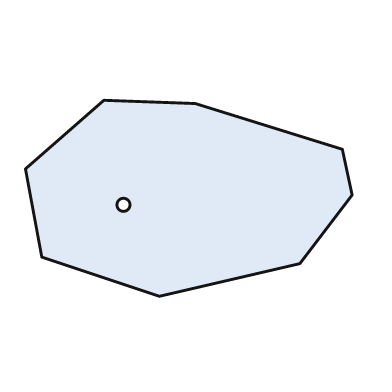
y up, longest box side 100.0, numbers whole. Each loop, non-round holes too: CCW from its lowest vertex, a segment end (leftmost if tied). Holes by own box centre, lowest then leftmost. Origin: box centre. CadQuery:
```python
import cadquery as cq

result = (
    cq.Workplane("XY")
    .moveTo(-9.0, -30.0)
    .lineTo(34.0, -20.0)
    .lineTo(50.0, 1.0)
    .lineTo(47.0, 15.0)
    .lineTo(2.0, 29.0)
    .lineTo(-26.0, 30.0)
    .lineTo(-50.0, 9.0)
    .lineTo(-45.0, -18.0)
    .close()
    .moveTo(-20.0, -2.0)
    .circle(2.0)
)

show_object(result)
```